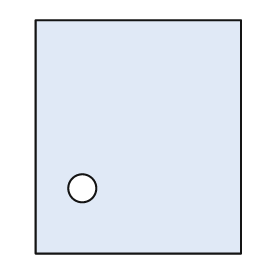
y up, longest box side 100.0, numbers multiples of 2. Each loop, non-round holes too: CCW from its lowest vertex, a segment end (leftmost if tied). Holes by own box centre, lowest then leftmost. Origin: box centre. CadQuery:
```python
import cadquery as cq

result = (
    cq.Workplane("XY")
    .moveTo(-44.0, -50.0)
    .lineTo(44.0, -50.0)
    .lineTo(44.0, 50.0)
    .lineTo(-44.0, 50.0)
    .close()
    .moveTo(-24.0, -22.0)
    .circle(6.0)
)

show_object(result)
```